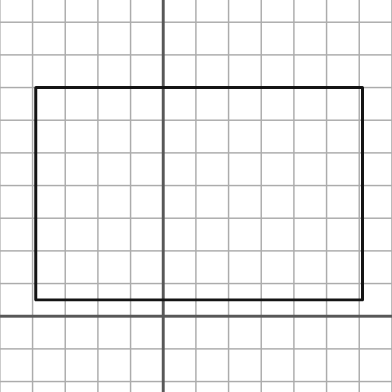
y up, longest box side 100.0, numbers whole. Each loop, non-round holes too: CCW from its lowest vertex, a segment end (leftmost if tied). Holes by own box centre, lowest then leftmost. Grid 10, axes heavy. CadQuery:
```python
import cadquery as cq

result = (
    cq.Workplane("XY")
    .moveTo(-39.0, 5.0)
    .lineTo(61.0, 5.0)
    .lineTo(61.0, 70.0)
    .lineTo(-39.0, 70.0)
    .close()
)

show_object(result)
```